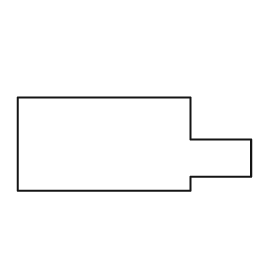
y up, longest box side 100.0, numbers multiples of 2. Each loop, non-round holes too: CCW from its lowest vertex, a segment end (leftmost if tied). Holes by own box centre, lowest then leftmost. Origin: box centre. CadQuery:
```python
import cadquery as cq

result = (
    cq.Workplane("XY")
    .moveTo(-50.0, -20.0)
    .lineTo(24.0, -20.0)
    .lineTo(24.0, -14.0)
    .lineTo(50.0, -14.0)
    .lineTo(50.0, 2.0)
    .lineTo(24.0, 2.0)
    .lineTo(24.0, 20.0)
    .lineTo(-50.0, 20.0)
    .close()
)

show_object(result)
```